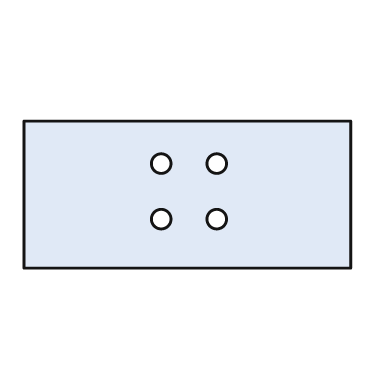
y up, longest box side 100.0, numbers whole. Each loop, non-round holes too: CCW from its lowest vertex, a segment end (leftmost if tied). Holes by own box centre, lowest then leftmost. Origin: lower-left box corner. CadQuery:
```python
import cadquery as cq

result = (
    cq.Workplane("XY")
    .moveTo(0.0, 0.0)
    .lineTo(100.0, 0.0)
    .lineTo(100.0, 45.0)
    .lineTo(0.0, 45.0)
    .close()
    .moveTo(42.0, 15.0)
    .circle(3.0)
    .moveTo(59.0, 15.0)
    .circle(3.0)
    .moveTo(42.0, 32.0)
    .circle(3.0)
    .moveTo(59.0, 32.0)
    .circle(3.0)
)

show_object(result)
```